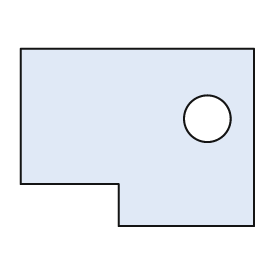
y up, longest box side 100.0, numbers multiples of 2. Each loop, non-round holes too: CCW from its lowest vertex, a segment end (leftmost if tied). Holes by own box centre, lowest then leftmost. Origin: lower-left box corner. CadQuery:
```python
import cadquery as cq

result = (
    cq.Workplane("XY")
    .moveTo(42.0, 0.0)
    .lineTo(100.0, 0.0)
    .lineTo(100.0, 76.0)
    .lineTo(0.0, 76.0)
    .lineTo(0.0, 18.0)
    .lineTo(42.0, 18.0)
    .close()
    .moveTo(80.0, 46.0)
    .circle(10.0)
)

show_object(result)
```